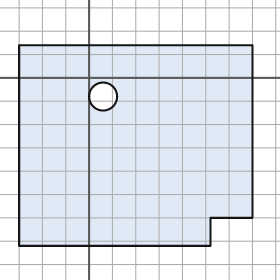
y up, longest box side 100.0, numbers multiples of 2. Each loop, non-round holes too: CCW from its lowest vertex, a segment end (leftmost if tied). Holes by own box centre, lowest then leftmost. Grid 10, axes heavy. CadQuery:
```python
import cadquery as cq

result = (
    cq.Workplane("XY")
    .moveTo(-30.0, -72.0)
    .lineTo(52.0, -72.0)
    .lineTo(52.0, -60.0)
    .lineTo(70.0, -60.0)
    .lineTo(70.0, 14.0)
    .lineTo(-30.0, 14.0)
    .close()
    .moveTo(6.0, -8.0)
    .circle(6.0)
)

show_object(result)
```